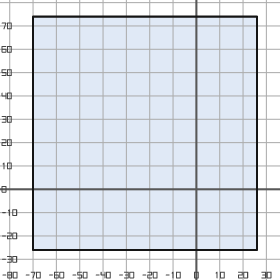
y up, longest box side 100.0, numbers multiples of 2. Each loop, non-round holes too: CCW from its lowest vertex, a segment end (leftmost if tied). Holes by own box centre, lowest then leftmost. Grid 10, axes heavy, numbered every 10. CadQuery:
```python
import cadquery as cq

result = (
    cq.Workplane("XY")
    .moveTo(-70.0, -26.0)
    .lineTo(26.0, -26.0)
    .lineTo(26.0, 74.0)
    .lineTo(-70.0, 74.0)
    .close()
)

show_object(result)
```